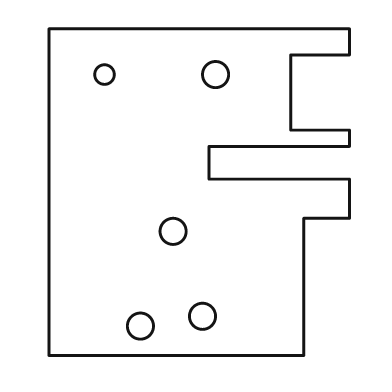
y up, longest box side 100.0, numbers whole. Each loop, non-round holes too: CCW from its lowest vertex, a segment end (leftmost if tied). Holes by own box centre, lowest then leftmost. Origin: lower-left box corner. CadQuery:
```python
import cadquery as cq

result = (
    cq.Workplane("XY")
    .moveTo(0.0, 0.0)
    .lineTo(78.0, 0.0)
    .lineTo(78.0, 42.0)
    .lineTo(92.0, 42.0)
    .lineTo(92.0, 54.0)
    .lineTo(49.0, 54.0)
    .lineTo(49.0, 64.0)
    .lineTo(92.0, 64.0)
    .lineTo(92.0, 69.0)
    .lineTo(74.0, 69.0)
    .lineTo(74.0, 92.0)
    .lineTo(92.0, 92.0)
    .lineTo(92.0, 100.0)
    .lineTo(0.0, 100.0)
    .close()
    .moveTo(28.0, 9.0)
    .circle(4.0)
    .moveTo(47.0, 12.0)
    .circle(4.0)
    .moveTo(38.0, 38.0)
    .circle(4.0)
    .moveTo(17.0, 86.0)
    .circle(3.0)
    .moveTo(51.0, 86.0)
    .circle(4.0)
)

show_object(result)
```